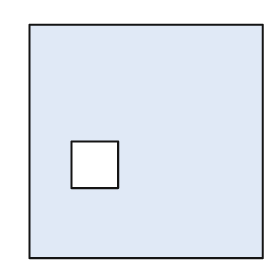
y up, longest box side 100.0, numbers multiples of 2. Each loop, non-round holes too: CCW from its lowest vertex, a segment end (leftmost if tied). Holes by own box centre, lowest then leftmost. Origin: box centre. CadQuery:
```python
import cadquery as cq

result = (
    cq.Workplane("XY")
    .moveTo(-50.0, -50.0)
    .lineTo(50.0, -50.0)
    .lineTo(50.0, 50.0)
    .lineTo(-50.0, 50.0)
    .close()
    .moveTo(-32.0, -20.0)
    .lineTo(-12.0, -20.0)
    .lineTo(-12.0, 0.0)
    .lineTo(-32.0, 0.0)
    .close()
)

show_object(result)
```